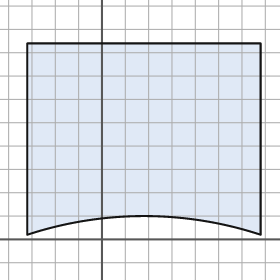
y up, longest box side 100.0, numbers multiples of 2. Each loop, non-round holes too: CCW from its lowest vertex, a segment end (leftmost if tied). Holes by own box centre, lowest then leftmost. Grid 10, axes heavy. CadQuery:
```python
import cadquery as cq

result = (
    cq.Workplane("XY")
    .moveTo(-32.0, 2.0)
    .threePointArc((18.0, 10.0), (68.0, 2.0))
    .lineTo(68.0, 84.0)
    .lineTo(-32.0, 84.0)
    .close()
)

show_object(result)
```